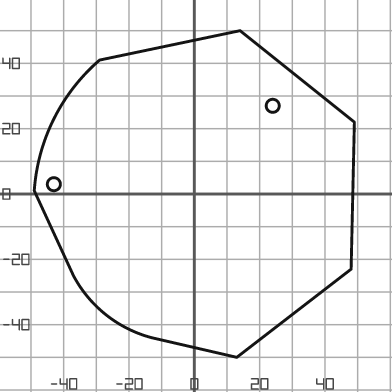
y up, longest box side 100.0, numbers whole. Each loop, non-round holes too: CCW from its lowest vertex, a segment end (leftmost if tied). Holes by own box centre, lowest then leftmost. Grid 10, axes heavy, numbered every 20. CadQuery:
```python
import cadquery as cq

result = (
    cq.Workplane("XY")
    .moveTo(13.0, -50.0)
    .lineTo(48.0, -23.0)
    .lineTo(49.0, 22.0)
    .lineTo(14.0, 50.0)
    .lineTo(-29.0, 41.0)
    .threePointArc((-43.0, 23.0), (-49.0, 1.0))
    .lineTo(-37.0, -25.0)
    .threePointArc((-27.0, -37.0), (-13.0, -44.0))
    .close()
    .moveTo(-43.0, 3.0)
    .circle(2.0)
    .moveTo(24.0, 27.0)
    .circle(2.0)
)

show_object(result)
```